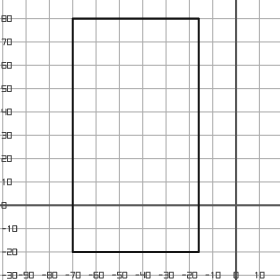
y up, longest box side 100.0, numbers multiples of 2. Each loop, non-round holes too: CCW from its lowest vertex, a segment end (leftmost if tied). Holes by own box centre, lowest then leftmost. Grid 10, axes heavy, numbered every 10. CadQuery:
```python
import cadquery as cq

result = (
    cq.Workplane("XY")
    .moveTo(-70.0, -20.0)
    .lineTo(-16.0, -20.0)
    .lineTo(-16.0, 80.0)
    .lineTo(-70.0, 80.0)
    .close()
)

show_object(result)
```